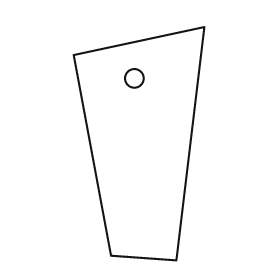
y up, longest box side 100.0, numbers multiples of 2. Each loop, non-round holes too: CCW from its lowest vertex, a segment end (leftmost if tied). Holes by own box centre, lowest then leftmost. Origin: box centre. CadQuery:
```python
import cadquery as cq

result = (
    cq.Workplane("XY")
    .moveTo(16.0, -50.0)
    .lineTo(28.0, 50.0)
    .lineTo(-28.0, 38.0)
    .lineTo(-12.0, -48.0)
    .close()
    .moveTo(-2.0, 28.0)
    .circle(4.0)
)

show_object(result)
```